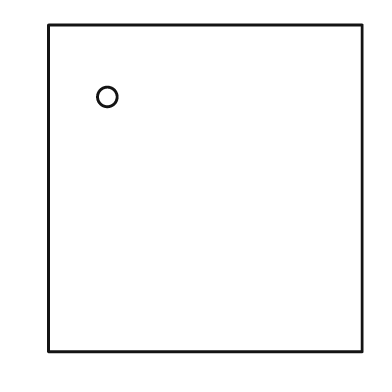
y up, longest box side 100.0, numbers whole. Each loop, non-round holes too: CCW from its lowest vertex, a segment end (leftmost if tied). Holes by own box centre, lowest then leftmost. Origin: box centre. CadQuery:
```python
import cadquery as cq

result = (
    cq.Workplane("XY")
    .moveTo(-48.0, -50.0)
    .lineTo(48.0, -50.0)
    .lineTo(48.0, 50.0)
    .lineTo(-48.0, 50.0)
    .close()
    .moveTo(-30.0, 28.0)
    .circle(3.0)
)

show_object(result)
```